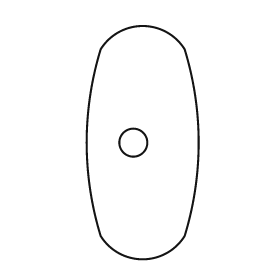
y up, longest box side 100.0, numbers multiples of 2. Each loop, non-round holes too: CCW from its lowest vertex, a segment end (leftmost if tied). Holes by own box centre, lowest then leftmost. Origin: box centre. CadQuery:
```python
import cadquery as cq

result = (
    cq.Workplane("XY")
    .moveTo(-18.0, -40.0)
    .threePointArc((0.0, -50.0), (18.0, -40.0))
    .threePointArc((24.0, 0.0), (18.0, 40.0))
    .threePointArc((0.0, 50.0), (-18.0, 40.0))
    .threePointArc((-24.0, 0.0), (-18.0, -40.0))
    .close()
    .moveTo(-4.0, 0.0)
    .circle(6.0)
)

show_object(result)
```